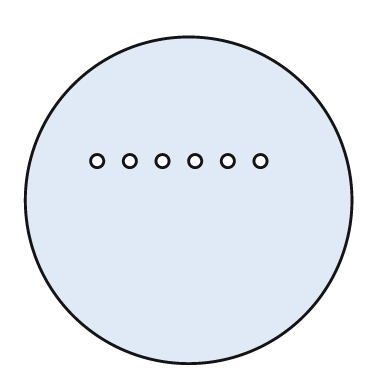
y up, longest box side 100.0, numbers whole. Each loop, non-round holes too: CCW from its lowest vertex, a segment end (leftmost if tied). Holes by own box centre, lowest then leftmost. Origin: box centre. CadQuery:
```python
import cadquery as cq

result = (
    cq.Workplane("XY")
    .moveTo(0.0, 0.0)
    .circle(50.0)
    .moveTo(-28.0, 12.0)
    .circle(2.0)
    .moveTo(-18.0, 12.0)
    .circle(2.0)
    .moveTo(-8.0, 12.0)
    .circle(2.0)
    .moveTo(2.0, 12.0)
    .circle(2.0)
    .moveTo(12.0, 12.0)
    .circle(2.0)
    .moveTo(22.0, 12.0)
    .circle(2.0)
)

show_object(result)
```